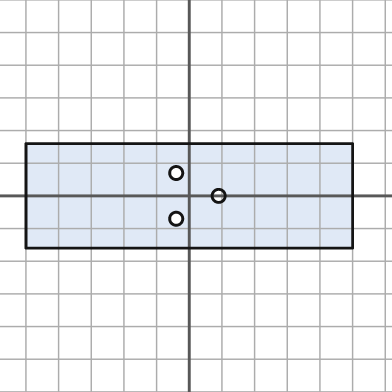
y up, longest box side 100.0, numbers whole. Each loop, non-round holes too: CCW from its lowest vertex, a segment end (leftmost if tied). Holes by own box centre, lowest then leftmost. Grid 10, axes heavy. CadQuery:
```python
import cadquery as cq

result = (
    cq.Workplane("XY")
    .moveTo(-50.0, -16.0)
    .lineTo(50.0, -16.0)
    .lineTo(50.0, 16.0)
    .lineTo(-50.0, 16.0)
    .close()
    .moveTo(-4.0, -7.0)
    .circle(2.0)
    .moveTo(9.0, 0.0)
    .circle(2.0)
    .moveTo(-4.0, 7.0)
    .circle(2.0)
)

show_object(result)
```